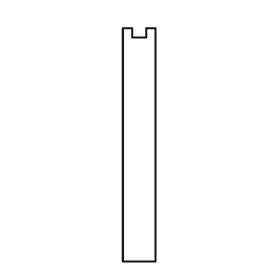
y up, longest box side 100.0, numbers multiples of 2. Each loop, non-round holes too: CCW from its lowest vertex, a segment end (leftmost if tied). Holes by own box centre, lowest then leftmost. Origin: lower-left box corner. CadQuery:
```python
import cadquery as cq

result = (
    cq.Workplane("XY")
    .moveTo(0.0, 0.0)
    .lineTo(14.0, 0.0)
    .lineTo(14.0, 100.0)
    .lineTo(10.0, 100.0)
    .lineTo(10.0, 96.0)
    .lineTo(4.0, 96.0)
    .lineTo(4.0, 100.0)
    .lineTo(0.0, 100.0)
    .close()
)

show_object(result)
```